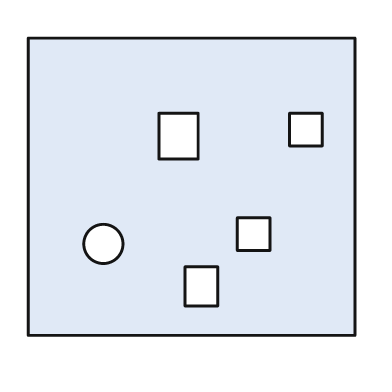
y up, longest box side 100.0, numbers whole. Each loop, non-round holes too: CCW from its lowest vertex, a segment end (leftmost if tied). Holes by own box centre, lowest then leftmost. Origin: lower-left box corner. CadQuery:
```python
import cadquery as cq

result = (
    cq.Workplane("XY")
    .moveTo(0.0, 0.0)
    .lineTo(100.0, 0.0)
    .lineTo(100.0, 91.0)
    .lineTo(0.0, 91.0)
    .close()
    .moveTo(48.0, 9.0)
    .lineTo(58.0, 9.0)
    .lineTo(58.0, 21.0)
    .lineTo(48.0, 21.0)
    .close()
    .moveTo(23.0, 28.0)
    .circle(6.0)
    .moveTo(64.0, 26.0)
    .lineTo(74.0, 26.0)
    .lineTo(74.0, 36.0)
    .lineTo(64.0, 36.0)
    .close()
    .moveTo(40.0, 54.0)
    .lineTo(52.0, 54.0)
    .lineTo(52.0, 68.0)
    .lineTo(40.0, 68.0)
    .close()
    .moveTo(80.0, 58.0)
    .lineTo(90.0, 58.0)
    .lineTo(90.0, 68.0)
    .lineTo(80.0, 68.0)
    .close()
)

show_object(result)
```